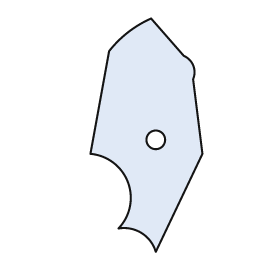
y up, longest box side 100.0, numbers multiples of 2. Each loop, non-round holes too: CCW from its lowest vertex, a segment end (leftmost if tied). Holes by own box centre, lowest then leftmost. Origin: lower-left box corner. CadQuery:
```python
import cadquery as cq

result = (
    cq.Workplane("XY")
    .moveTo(28.0, 0.0)
    .lineTo(48.0, 42.0)
    .lineTo(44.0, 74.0)
    .threePointArc((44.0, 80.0), (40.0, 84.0))
    .lineTo(26.0, 100.0)
    .threePointArc((16.0, 94.0), (8.0, 86.0))
    .lineTo(0.0, 42.0)
    .threePointArc((16.0, 30.0), (12.0, 10.0))
    .threePointArc((22.0, 8.0), (28.0, 0.0))
    .close()
    .moveTo(28.0, 48.0)
    .circle(4.0)
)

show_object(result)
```